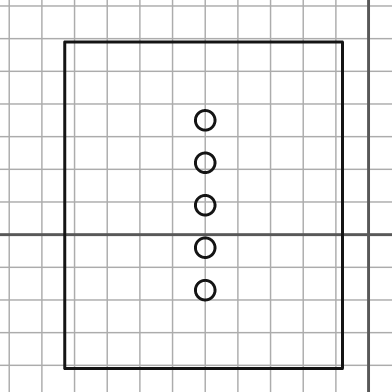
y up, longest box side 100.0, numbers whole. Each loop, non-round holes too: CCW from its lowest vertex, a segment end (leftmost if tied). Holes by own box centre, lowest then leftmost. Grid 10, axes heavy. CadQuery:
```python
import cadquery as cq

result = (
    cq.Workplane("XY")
    .moveTo(-93.0, -41.0)
    .lineTo(-8.0, -41.0)
    .lineTo(-8.0, 59.0)
    .lineTo(-93.0, 59.0)
    .close()
    .moveTo(-50.0, -17.0)
    .circle(3.0)
    .moveTo(-50.0, -4.0)
    .circle(3.0)
    .moveTo(-50.0, 9.0)
    .circle(3.0)
    .moveTo(-50.0, 22.0)
    .circle(3.0)
    .moveTo(-50.0, 35.0)
    .circle(3.0)
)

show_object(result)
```